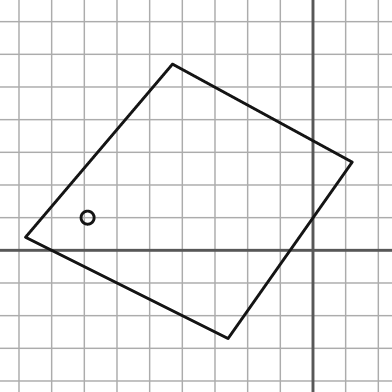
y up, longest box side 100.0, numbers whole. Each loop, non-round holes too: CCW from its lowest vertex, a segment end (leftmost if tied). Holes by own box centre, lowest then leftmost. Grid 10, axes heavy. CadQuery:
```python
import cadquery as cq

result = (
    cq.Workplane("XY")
    .moveTo(-26.0, -27.0)
    .lineTo(12.0, 27.0)
    .lineTo(-43.0, 57.0)
    .lineTo(-88.0, 4.0)
    .close()
    .moveTo(-69.0, 10.0)
    .circle(2.0)
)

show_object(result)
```